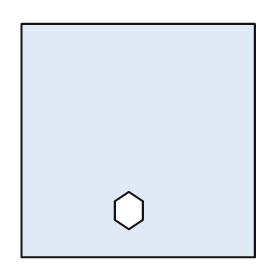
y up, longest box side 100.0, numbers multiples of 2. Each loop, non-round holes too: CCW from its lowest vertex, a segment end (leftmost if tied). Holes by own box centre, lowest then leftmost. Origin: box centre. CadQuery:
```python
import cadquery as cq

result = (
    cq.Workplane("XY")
    .moveTo(-50.0, -50.0)
    .lineTo(50.0, -50.0)
    .lineTo(50.0, 50.0)
    .lineTo(-50.0, 50.0)
    .close()
    .moveTo(-4.0, -38.0)
    .lineTo(2.0, -34.0)
    .lineTo(2.0, -26.0)
    .lineTo(-4.0, -22.0)
    .lineTo(-10.0, -26.0)
    .lineTo(-10.0, -34.0)
    .close()
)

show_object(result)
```